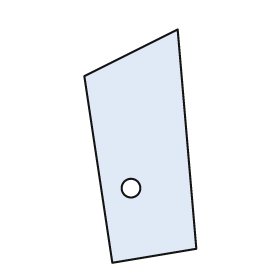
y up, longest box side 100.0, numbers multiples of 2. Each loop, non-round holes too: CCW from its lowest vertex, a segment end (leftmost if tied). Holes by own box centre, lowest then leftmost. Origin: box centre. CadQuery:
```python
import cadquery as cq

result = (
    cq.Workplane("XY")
    .moveTo(-12.0, -50.0)
    .lineTo(24.0, -44.0)
    .lineTo(16.0, 50.0)
    .lineTo(-24.0, 30.0)
    .close()
    .moveTo(-4.0, -18.0)
    .circle(4.0)
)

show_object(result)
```